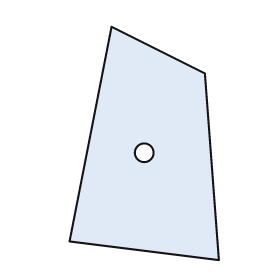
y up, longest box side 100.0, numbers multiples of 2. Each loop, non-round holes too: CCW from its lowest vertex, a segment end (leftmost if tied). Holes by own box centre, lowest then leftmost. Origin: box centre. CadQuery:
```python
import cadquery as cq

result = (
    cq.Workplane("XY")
    .moveTo(32.0, -50.0)
    .lineTo(26.0, 30.0)
    .lineTo(-14.0, 50.0)
    .lineTo(-32.0, -42.0)
    .close()
    .moveTo(0.0, -4.0)
    .circle(4.0)
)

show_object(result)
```